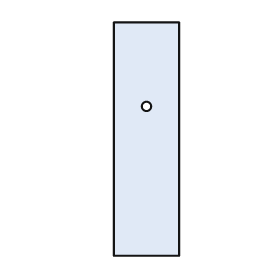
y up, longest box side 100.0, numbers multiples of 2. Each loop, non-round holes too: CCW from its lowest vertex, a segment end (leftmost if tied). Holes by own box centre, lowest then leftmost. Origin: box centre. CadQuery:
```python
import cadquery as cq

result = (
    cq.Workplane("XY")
    .moveTo(-14.0, -50.0)
    .lineTo(14.0, -50.0)
    .lineTo(14.0, 50.0)
    .lineTo(-14.0, 50.0)
    .close()
    .moveTo(0.0, 14.0)
    .circle(2.0)
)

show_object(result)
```